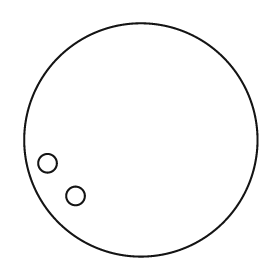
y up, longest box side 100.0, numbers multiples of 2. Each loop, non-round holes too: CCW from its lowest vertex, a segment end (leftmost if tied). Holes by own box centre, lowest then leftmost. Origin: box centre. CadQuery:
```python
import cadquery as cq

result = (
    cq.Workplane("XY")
    .moveTo(0.0, 0.0)
    .circle(50.0)
    .moveTo(-28.0, -24.0)
    .circle(4.0)
    .moveTo(-40.0, -10.0)
    .circle(4.0)
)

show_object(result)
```